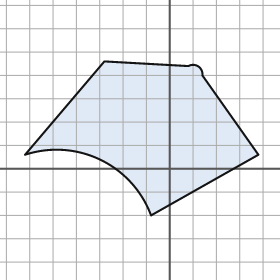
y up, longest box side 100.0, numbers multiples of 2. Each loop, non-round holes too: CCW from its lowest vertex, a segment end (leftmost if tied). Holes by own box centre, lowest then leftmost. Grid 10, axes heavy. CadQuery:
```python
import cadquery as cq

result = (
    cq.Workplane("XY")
    .moveTo(-8.0, -20.0)
    .lineTo(38.0, 6.0)
    .lineTo(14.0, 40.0)
    .threePointArc((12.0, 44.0), (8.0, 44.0))
    .lineTo(-28.0, 46.0)
    .lineTo(-62.0, 6.0)
    .threePointArc((-30.0, 4.0), (-8.0, -20.0))
    .close()
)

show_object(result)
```